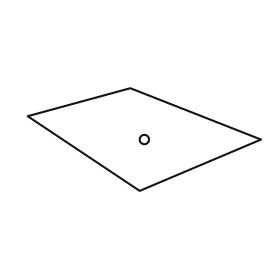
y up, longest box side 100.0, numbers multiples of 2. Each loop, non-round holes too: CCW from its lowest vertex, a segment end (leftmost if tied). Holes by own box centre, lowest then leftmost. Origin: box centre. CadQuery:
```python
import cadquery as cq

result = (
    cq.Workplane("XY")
    .moveTo(-2.0, -22.0)
    .lineTo(50.0, 0.0)
    .lineTo(-6.0, 22.0)
    .lineTo(-50.0, 10.0)
    .close()
    .moveTo(0.0, 0.0)
    .circle(2.0)
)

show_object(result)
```